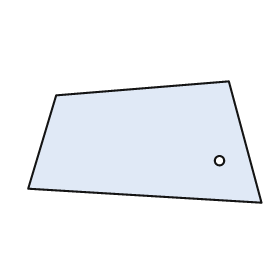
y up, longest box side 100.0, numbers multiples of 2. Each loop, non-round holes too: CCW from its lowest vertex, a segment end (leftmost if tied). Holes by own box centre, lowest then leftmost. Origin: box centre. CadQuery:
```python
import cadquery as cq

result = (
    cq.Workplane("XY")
    .moveTo(50.0, -26.0)
    .lineTo(36.0, 26.0)
    .lineTo(-38.0, 20.0)
    .lineTo(-50.0, -20.0)
    .close()
    .moveTo(32.0, -8.0)
    .circle(2.0)
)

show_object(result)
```